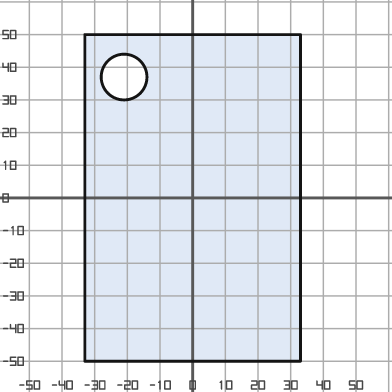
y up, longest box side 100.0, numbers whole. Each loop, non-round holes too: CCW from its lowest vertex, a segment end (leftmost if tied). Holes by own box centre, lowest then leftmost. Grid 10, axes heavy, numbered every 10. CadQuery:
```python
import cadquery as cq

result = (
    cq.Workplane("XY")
    .moveTo(-33.0, -50.0)
    .lineTo(33.0, -50.0)
    .lineTo(33.0, 50.0)
    .lineTo(-33.0, 50.0)
    .close()
    .moveTo(-21.0, 37.0)
    .circle(7.0)
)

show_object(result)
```